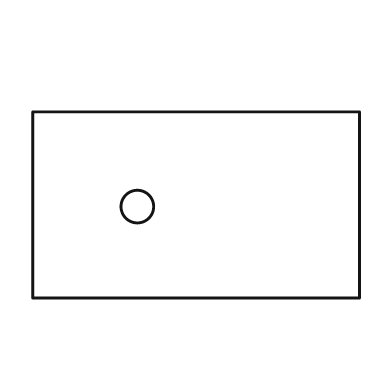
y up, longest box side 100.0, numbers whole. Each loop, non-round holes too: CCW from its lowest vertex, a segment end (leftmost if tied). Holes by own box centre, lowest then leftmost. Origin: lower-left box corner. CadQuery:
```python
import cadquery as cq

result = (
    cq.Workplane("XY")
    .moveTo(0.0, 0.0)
    .lineTo(100.0, 0.0)
    .lineTo(100.0, 57.0)
    .lineTo(0.0, 57.0)
    .close()
    .moveTo(32.0, 28.0)
    .circle(5.0)
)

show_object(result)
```